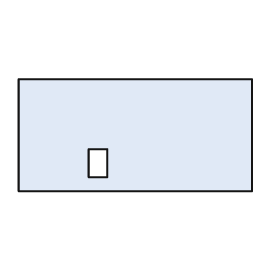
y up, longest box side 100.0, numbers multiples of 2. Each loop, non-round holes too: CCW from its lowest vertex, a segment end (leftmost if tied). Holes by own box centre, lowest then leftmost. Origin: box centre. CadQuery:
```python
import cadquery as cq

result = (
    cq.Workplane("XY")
    .moveTo(-50.0, -24.0)
    .lineTo(50.0, -24.0)
    .lineTo(50.0, 24.0)
    .lineTo(-50.0, 24.0)
    .close()
    .moveTo(-20.0, -18.0)
    .lineTo(-12.0, -18.0)
    .lineTo(-12.0, -6.0)
    .lineTo(-20.0, -6.0)
    .close()
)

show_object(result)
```